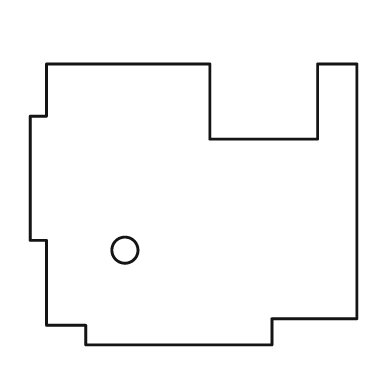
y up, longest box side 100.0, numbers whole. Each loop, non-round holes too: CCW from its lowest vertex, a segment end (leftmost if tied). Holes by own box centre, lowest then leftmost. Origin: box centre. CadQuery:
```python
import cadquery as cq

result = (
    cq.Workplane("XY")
    .moveTo(-33.0, -43.0)
    .lineTo(24.0, -43.0)
    .lineTo(24.0, -35.0)
    .lineTo(50.0, -35.0)
    .lineTo(50.0, 43.0)
    .lineTo(38.0, 43.0)
    .lineTo(38.0, 20.0)
    .lineTo(5.0, 20.0)
    .lineTo(5.0, 43.0)
    .lineTo(-45.0, 43.0)
    .lineTo(-45.0, 27.0)
    .lineTo(-50.0, 27.0)
    .lineTo(-50.0, -11.0)
    .lineTo(-45.0, -11.0)
    .lineTo(-45.0, -37.0)
    .lineTo(-33.0, -37.0)
    .close()
    .moveTo(-21.0, -14.0)
    .circle(4.0)
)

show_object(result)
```